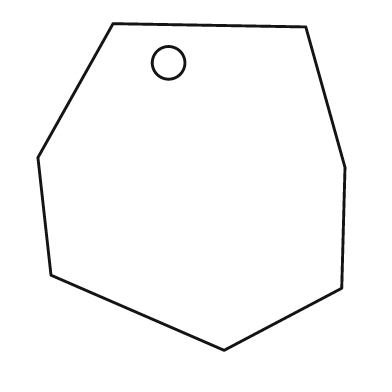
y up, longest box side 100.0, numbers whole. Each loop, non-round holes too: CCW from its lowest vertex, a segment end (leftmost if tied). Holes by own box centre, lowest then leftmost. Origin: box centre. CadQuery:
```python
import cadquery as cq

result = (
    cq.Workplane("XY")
    .moveTo(10.0, -50.0)
    .lineTo(46.0, -31.0)
    .lineTo(47.0, 6.0)
    .lineTo(35.0, 49.0)
    .lineTo(-24.0, 50.0)
    .lineTo(-47.0, 9.0)
    .lineTo(-43.0, -27.0)
    .close()
    .moveTo(-7.0, 38.0)
    .circle(5.0)
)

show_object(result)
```